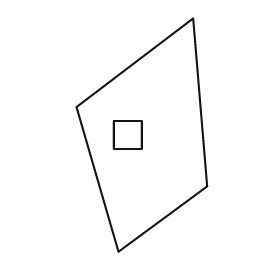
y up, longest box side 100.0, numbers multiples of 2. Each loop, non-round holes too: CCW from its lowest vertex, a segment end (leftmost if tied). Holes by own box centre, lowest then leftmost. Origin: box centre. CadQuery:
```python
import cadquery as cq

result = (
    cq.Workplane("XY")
    .moveTo(-10.0, -50.0)
    .lineTo(28.0, -22.0)
    .lineTo(22.0, 50.0)
    .lineTo(-28.0, 12.0)
    .close()
    .moveTo(-12.0, -6.0)
    .lineTo(0.0, -6.0)
    .lineTo(0.0, 6.0)
    .lineTo(-12.0, 6.0)
    .close()
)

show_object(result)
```